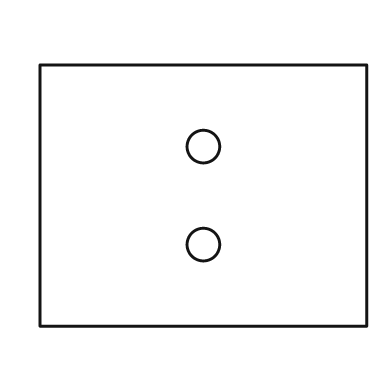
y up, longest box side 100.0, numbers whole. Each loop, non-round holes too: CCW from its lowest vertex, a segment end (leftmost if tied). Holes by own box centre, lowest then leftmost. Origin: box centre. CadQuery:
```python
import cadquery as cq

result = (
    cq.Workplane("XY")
    .moveTo(-50.0, -40.0)
    .lineTo(50.0, -40.0)
    .lineTo(50.0, 40.0)
    .lineTo(-50.0, 40.0)
    .close()
    .moveTo(0.0, -15.0)
    .circle(5.0)
    .moveTo(0.0, 15.0)
    .circle(5.0)
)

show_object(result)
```